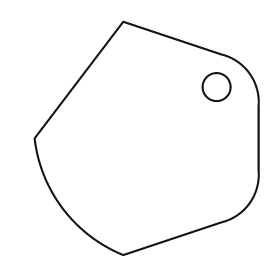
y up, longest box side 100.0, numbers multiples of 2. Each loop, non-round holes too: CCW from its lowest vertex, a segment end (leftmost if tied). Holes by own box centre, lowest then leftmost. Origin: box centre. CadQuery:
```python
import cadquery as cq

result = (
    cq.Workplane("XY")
    .moveTo(-10.0, -50.0)
    .lineTo(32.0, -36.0)
    .threePointArc((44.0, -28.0), (48.0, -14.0))
    .lineTo(48.0, 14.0)
    .threePointArc((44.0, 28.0), (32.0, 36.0))
    .lineTo(-10.0, 50.0)
    .lineTo(-48.0, 0.0)
    .threePointArc((-36.0, -30.0), (-10.0, -50.0))
    .close()
    .moveTo(30.0, 22.0)
    .circle(6.0)
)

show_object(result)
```